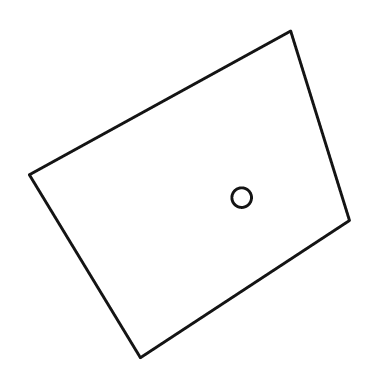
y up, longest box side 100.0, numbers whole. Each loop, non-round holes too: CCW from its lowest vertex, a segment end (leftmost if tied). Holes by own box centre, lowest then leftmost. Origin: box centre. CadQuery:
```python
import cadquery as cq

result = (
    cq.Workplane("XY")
    .moveTo(-15.0, -50.0)
    .lineTo(49.0, -8.0)
    .lineTo(31.0, 50.0)
    .lineTo(-49.0, 6.0)
    .close()
    .moveTo(16.0, -1.0)
    .circle(3.0)
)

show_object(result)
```